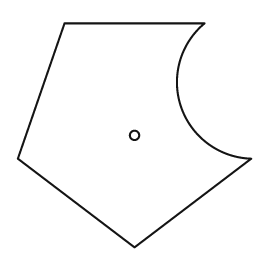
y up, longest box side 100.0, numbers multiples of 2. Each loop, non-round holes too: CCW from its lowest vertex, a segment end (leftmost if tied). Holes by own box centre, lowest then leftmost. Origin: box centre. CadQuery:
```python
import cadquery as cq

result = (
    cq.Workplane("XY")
    .moveTo(0.0, -48.0)
    .lineTo(50.0, -10.0)
    .threePointArc((20.0, 12.0), (30.0, 48.0))
    .lineTo(-30.0, 48.0)
    .lineTo(-50.0, -10.0)
    .close()
    .moveTo(0.0, 0.0)
    .circle(2.0)
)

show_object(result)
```